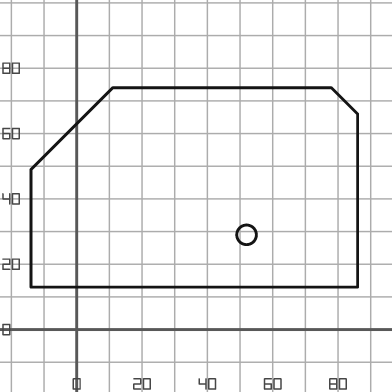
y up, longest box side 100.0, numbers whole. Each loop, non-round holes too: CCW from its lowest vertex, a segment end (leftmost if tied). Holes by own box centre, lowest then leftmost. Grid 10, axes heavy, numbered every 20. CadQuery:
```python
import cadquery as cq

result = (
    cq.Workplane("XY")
    .moveTo(-14.0, 13.0)
    .lineTo(86.0, 13.0)
    .lineTo(86.0, 66.0)
    .lineTo(78.0, 74.0)
    .lineTo(11.0, 74.0)
    .lineTo(-14.0, 49.0)
    .close()
    .moveTo(52.0, 29.0)
    .circle(3.0)
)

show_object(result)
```